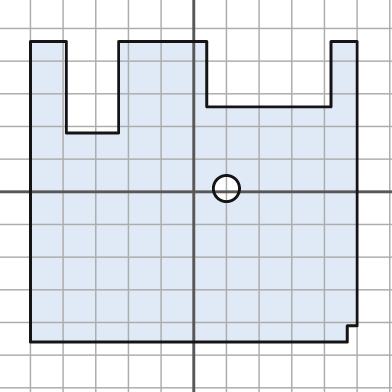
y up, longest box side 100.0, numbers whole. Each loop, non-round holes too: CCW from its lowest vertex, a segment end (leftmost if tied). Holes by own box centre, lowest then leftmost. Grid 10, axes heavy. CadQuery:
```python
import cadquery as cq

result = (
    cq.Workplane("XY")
    .moveTo(-50.0, -46.0)
    .lineTo(47.0, -46.0)
    .lineTo(47.0, -41.0)
    .lineTo(50.0, -41.0)
    .lineTo(50.0, 46.0)
    .lineTo(42.0, 46.0)
    .lineTo(42.0, 26.0)
    .lineTo(4.0, 26.0)
    .lineTo(4.0, 46.0)
    .lineTo(-23.0, 46.0)
    .lineTo(-23.0, 18.0)
    .lineTo(-39.0, 18.0)
    .lineTo(-39.0, 46.0)
    .lineTo(-50.0, 46.0)
    .close()
    .moveTo(10.0, 1.0)
    .circle(4.0)
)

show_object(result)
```